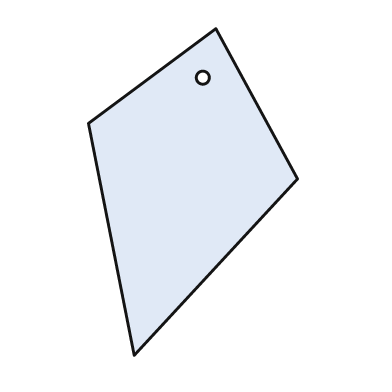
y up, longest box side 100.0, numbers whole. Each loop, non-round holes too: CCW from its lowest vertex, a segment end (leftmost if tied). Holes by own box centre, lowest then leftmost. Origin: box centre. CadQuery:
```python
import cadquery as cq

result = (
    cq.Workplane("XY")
    .moveTo(-18.0, -50.0)
    .lineTo(32.0, 4.0)
    .lineTo(7.0, 50.0)
    .lineTo(-32.0, 21.0)
    .close()
    .moveTo(3.0, 35.0)
    .circle(2.0)
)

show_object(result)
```